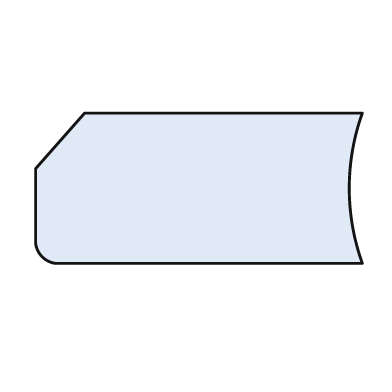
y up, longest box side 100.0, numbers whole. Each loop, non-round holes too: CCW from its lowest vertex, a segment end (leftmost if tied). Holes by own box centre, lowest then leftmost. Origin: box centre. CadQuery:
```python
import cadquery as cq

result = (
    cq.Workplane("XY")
    .moveTo(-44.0, -23.0)
    .lineTo(50.0, -23.0)
    .threePointArc((46.0, 0.0), (50.0, 23.0))
    .lineTo(-35.0, 23.0)
    .lineTo(-50.0, 6.0)
    .lineTo(-50.0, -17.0)
    .threePointArc((-48.0, -21.0), (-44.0, -23.0))
    .close()
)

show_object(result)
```